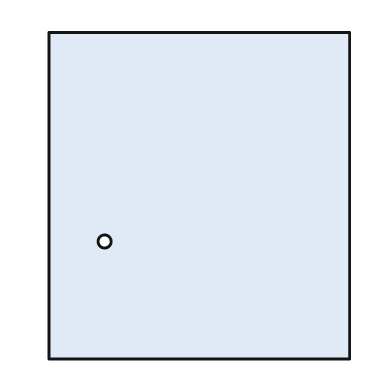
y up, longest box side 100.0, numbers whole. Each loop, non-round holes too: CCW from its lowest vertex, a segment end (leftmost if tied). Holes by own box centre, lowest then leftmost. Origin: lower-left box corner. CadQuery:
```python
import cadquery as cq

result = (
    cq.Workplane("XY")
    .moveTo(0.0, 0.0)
    .lineTo(92.0, 0.0)
    .lineTo(92.0, 100.0)
    .lineTo(0.0, 100.0)
    .close()
    .moveTo(17.0, 36.0)
    .circle(2.0)
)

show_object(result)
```